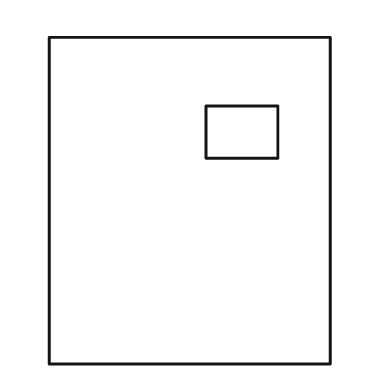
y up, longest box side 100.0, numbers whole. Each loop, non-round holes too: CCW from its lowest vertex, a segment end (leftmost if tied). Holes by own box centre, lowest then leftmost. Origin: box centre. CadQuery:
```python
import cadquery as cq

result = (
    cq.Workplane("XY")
    .moveTo(-43.0, -50.0)
    .lineTo(43.0, -50.0)
    .lineTo(43.0, 50.0)
    .lineTo(-43.0, 50.0)
    .close()
    .moveTo(5.0, 13.0)
    .lineTo(27.0, 13.0)
    .lineTo(27.0, 29.0)
    .lineTo(5.0, 29.0)
    .close()
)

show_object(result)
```